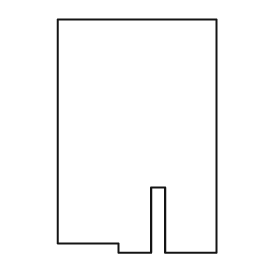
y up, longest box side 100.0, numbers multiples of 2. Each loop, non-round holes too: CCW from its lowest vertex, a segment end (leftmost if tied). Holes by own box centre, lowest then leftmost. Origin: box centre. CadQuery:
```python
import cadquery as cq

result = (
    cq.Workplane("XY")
    .moveTo(-8.0, -50.0)
    .lineTo(6.0, -50.0)
    .lineTo(6.0, -22.0)
    .lineTo(12.0, -22.0)
    .lineTo(12.0, -50.0)
    .lineTo(34.0, -50.0)
    .lineTo(34.0, 50.0)
    .lineTo(-34.0, 50.0)
    .lineTo(-34.0, -46.0)
    .lineTo(-8.0, -46.0)
    .close()
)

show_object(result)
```